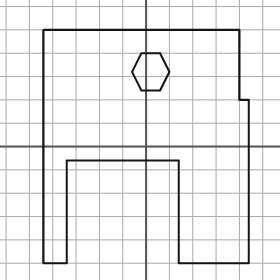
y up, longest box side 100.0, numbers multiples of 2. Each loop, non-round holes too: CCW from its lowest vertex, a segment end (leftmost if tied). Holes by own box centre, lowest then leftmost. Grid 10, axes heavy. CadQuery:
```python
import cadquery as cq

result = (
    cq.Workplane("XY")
    .moveTo(-44.0, -50.0)
    .lineTo(-34.0, -50.0)
    .lineTo(-34.0, -6.0)
    .lineTo(14.0, -6.0)
    .lineTo(14.0, -50.0)
    .lineTo(44.0, -50.0)
    .lineTo(44.0, 20.0)
    .lineTo(40.0, 20.0)
    .lineTo(40.0, 50.0)
    .lineTo(-44.0, 50.0)
    .close()
    .moveTo(-2.0, 24.0)
    .lineTo(6.0, 24.0)
    .lineTo(10.0, 32.0)
    .lineTo(6.0, 40.0)
    .lineTo(-2.0, 40.0)
    .lineTo(-6.0, 32.0)
    .close()
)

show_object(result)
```